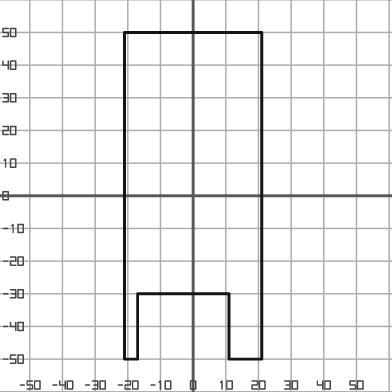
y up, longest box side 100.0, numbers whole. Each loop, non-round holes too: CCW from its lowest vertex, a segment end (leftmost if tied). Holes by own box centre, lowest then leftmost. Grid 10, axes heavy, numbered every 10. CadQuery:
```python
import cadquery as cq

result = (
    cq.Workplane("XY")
    .moveTo(-21.0, -50.0)
    .lineTo(-17.0, -50.0)
    .lineTo(-17.0, -30.0)
    .lineTo(11.0, -30.0)
    .lineTo(11.0, -50.0)
    .lineTo(21.0, -50.0)
    .lineTo(21.0, 50.0)
    .lineTo(-21.0, 50.0)
    .close()
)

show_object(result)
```